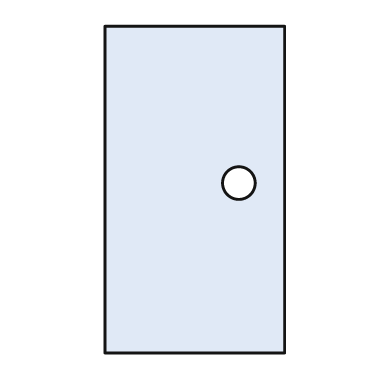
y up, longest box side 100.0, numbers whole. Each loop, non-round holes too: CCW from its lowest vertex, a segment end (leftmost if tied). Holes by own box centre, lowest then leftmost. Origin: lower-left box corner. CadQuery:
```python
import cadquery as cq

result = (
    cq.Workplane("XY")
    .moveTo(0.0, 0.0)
    .lineTo(55.0, 0.0)
    .lineTo(55.0, 100.0)
    .lineTo(0.0, 100.0)
    .close()
    .moveTo(41.0, 52.0)
    .circle(5.0)
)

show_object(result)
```